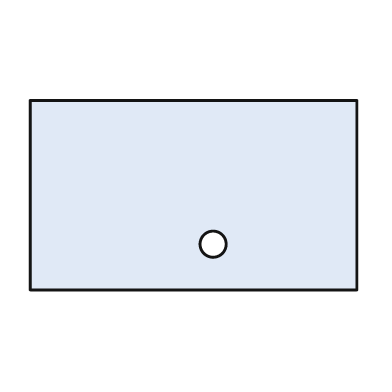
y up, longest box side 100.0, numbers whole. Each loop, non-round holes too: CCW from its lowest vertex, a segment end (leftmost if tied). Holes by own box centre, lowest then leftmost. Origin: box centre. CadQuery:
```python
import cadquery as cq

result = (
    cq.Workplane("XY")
    .moveTo(-50.0, -29.0)
    .lineTo(50.0, -29.0)
    .lineTo(50.0, 29.0)
    .lineTo(-50.0, 29.0)
    .close()
    .moveTo(6.0, -15.0)
    .circle(4.0)
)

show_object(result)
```